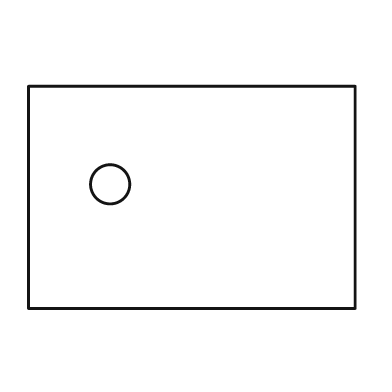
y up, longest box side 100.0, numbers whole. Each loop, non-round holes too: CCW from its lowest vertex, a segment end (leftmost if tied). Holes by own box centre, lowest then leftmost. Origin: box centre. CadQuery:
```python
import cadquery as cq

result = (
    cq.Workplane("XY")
    .moveTo(-50.0, -34.0)
    .lineTo(50.0, -34.0)
    .lineTo(50.0, 34.0)
    .lineTo(-50.0, 34.0)
    .close()
    .moveTo(-25.0, 4.0)
    .circle(6.0)
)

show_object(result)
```